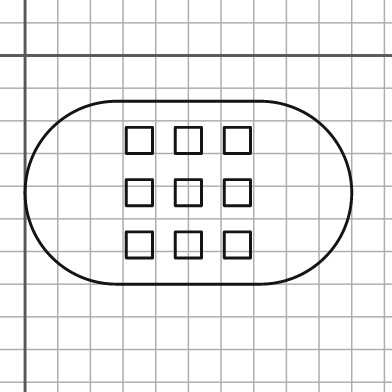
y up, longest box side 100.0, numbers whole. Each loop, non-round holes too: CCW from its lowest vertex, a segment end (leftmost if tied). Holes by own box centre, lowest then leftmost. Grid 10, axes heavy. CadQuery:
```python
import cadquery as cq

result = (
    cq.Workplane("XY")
    .moveTo(28.0, -70.0)
    .lineTo(72.0, -70.0)
    .threePointArc((100.0, -42.0), (72.0, -14.0))
    .lineTo(28.0, -14.0)
    .threePointArc((0.0, -42.0), (28.0, -70.0))
    .close()
    .moveTo(31.0, -62.0)
    .lineTo(39.0, -62.0)
    .lineTo(39.0, -54.0)
    .lineTo(31.0, -54.0)
    .close()
    .moveTo(46.0, -62.0)
    .lineTo(54.0, -62.0)
    .lineTo(54.0, -54.0)
    .lineTo(46.0, -54.0)
    .close()
    .moveTo(61.0, -62.0)
    .lineTo(69.0, -62.0)
    .lineTo(69.0, -54.0)
    .lineTo(61.0, -54.0)
    .close()
    .moveTo(31.0, -46.0)
    .lineTo(39.0, -46.0)
    .lineTo(39.0, -38.0)
    .lineTo(31.0, -38.0)
    .close()
    .moveTo(46.0, -46.0)
    .lineTo(54.0, -46.0)
    .lineTo(54.0, -38.0)
    .lineTo(46.0, -38.0)
    .close()
    .moveTo(61.0, -46.0)
    .lineTo(69.0, -46.0)
    .lineTo(69.0, -38.0)
    .lineTo(61.0, -38.0)
    .close()
    .moveTo(31.0, -30.0)
    .lineTo(39.0, -30.0)
    .lineTo(39.0, -22.0)
    .lineTo(31.0, -22.0)
    .close()
    .moveTo(46.0, -30.0)
    .lineTo(54.0, -30.0)
    .lineTo(54.0, -22.0)
    .lineTo(46.0, -22.0)
    .close()
    .moveTo(61.0, -30.0)
    .lineTo(69.0, -30.0)
    .lineTo(69.0, -22.0)
    .lineTo(61.0, -22.0)
    .close()
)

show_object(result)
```